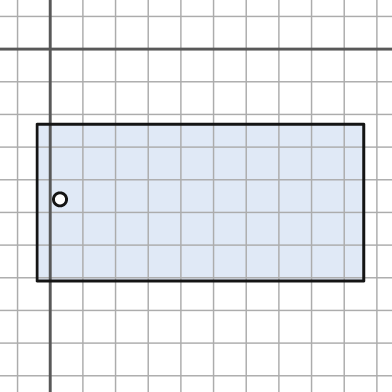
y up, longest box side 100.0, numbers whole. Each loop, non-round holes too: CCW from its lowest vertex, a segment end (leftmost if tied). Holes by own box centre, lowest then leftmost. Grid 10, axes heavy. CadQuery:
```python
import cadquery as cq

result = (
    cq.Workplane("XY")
    .moveTo(-4.0, -71.0)
    .lineTo(96.0, -71.0)
    .lineTo(96.0, -23.0)
    .lineTo(-4.0, -23.0)
    .close()
    .moveTo(3.0, -46.0)
    .circle(2.0)
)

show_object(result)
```